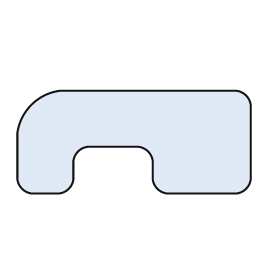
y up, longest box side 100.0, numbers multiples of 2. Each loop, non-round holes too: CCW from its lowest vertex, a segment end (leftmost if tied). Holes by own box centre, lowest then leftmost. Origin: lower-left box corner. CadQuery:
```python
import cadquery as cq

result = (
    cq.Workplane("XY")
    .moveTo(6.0, 0.0)
    .lineTo(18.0, 0.0)
    .threePointArc((22.0, 2.0), (24.0, 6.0))
    .lineTo(24.0, 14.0)
    .threePointArc((26.0, 18.0), (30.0, 20.0))
    .lineTo(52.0, 20.0)
    .threePointArc((56.0, 18.0), (58.0, 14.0))
    .lineTo(58.0, 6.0)
    .threePointArc((60.0, 2.0), (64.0, 0.0))
    .lineTo(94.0, 0.0)
    .threePointArc((98.0, 2.0), (100.0, 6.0))
    .lineTo(100.0, 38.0)
    .threePointArc((98.0, 42.0), (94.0, 44.0))
    .lineTo(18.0, 44.0)
    .threePointArc((6.0, 38.0), (0.0, 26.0))
    .lineTo(0.0, 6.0)
    .threePointArc((2.0, 2.0), (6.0, 0.0))
    .close()
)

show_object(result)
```